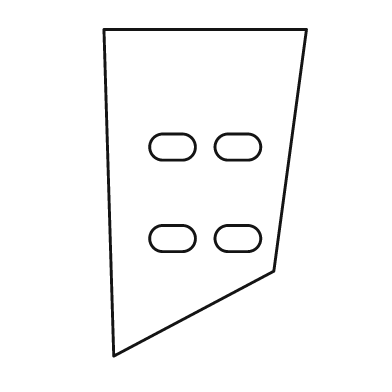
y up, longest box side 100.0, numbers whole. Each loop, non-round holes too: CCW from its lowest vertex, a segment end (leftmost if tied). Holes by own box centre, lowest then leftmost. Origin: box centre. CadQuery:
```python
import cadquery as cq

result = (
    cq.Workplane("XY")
    .moveTo(-28.0, -50.0)
    .lineTo(21.0, -24.0)
    .lineTo(31.0, 50.0)
    .lineTo(-31.0, 50.0)
    .close()
    .moveTo(-13.0, -18.0)
    .lineTo(-7.0, -18.0)
    .threePointArc((-3.0, -14.0), (-7.0, -10.0))
    .lineTo(-13.0, -10.0)
    .threePointArc((-17.0, -14.0), (-13.0, -18.0))
    .close()
    .moveTo(7.0, -18.0)
    .lineTo(13.0, -18.0)
    .threePointArc((17.0, -14.0), (13.0, -10.0))
    .lineTo(7.0, -10.0)
    .threePointArc((3.0, -14.0), (7.0, -18.0))
    .close()
    .moveTo(-13.0, 10.0)
    .lineTo(-7.0, 10.0)
    .threePointArc((-3.0, 14.0), (-7.0, 18.0))
    .lineTo(-13.0, 18.0)
    .threePointArc((-17.0, 14.0), (-13.0, 10.0))
    .close()
    .moveTo(7.0, 10.0)
    .lineTo(13.0, 10.0)
    .threePointArc((17.0, 14.0), (13.0, 18.0))
    .lineTo(7.0, 18.0)
    .threePointArc((3.0, 14.0), (7.0, 10.0))
    .close()
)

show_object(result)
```